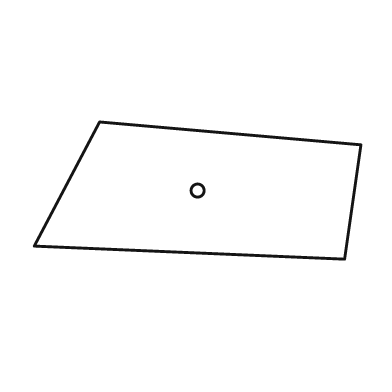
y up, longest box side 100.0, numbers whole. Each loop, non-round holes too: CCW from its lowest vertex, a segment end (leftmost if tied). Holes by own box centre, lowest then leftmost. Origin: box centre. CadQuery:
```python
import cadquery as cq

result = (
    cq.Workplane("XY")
    .moveTo(45.0, -21.0)
    .lineTo(50.0, 14.0)
    .lineTo(-30.0, 21.0)
    .lineTo(-50.0, -17.0)
    .close()
    .moveTo(0.0, 0.0)
    .circle(2.0)
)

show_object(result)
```